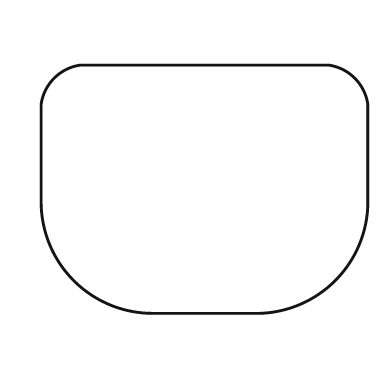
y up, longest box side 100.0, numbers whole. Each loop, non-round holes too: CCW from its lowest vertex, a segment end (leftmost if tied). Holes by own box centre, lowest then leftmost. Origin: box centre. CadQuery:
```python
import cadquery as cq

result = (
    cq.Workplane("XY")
    .moveTo(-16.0, -38.0)
    .lineTo(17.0, -38.0)
    .threePointArc((40.0, -28.0), (50.0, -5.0))
    .lineTo(50.0, 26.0)
    .threePointArc((46.0, 34.0), (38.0, 38.0))
    .lineTo(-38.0, 38.0)
    .threePointArc((-46.0, 34.0), (-50.0, 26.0))
    .lineTo(-50.0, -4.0)
    .threePointArc((-40.0, -28.0), (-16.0, -38.0))
    .close()
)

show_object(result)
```